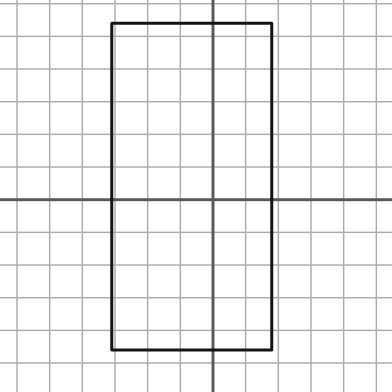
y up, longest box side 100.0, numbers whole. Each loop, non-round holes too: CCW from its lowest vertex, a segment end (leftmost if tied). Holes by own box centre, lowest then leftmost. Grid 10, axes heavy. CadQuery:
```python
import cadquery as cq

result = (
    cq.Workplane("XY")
    .moveTo(-31.0, -46.0)
    .lineTo(18.0, -46.0)
    .lineTo(18.0, 54.0)
    .lineTo(-31.0, 54.0)
    .close()
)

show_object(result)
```